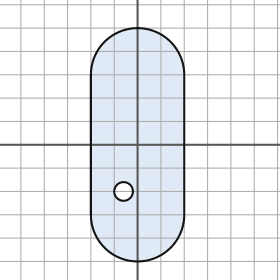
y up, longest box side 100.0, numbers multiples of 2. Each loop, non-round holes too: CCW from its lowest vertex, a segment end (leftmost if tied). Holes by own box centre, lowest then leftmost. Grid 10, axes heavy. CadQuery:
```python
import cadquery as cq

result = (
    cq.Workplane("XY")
    .moveTo(-20.0, -30.0)
    .threePointArc((0.0, -50.0), (20.0, -30.0))
    .lineTo(20.0, 30.0)
    .threePointArc((0.0, 50.0), (-20.0, 30.0))
    .close()
    .moveTo(-6.0, -20.0)
    .circle(4.0)
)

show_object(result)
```